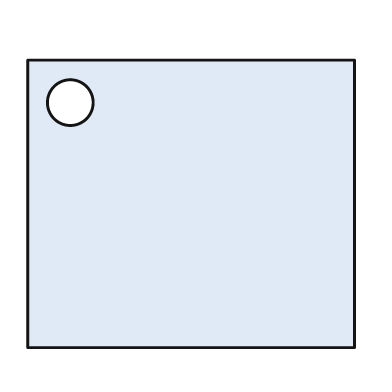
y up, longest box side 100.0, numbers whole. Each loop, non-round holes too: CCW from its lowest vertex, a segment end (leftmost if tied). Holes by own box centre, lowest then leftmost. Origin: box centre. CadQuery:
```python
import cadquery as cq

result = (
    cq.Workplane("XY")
    .moveTo(-50.0, -44.0)
    .lineTo(50.0, -44.0)
    .lineTo(50.0, 44.0)
    .lineTo(-50.0, 44.0)
    .close()
    .moveTo(-37.0, 31.0)
    .circle(7.0)
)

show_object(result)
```